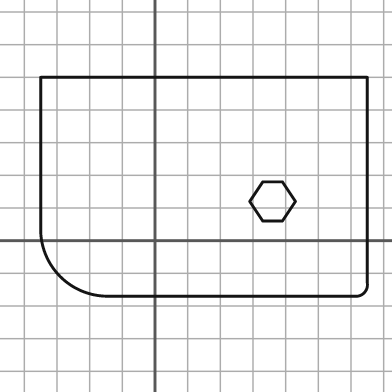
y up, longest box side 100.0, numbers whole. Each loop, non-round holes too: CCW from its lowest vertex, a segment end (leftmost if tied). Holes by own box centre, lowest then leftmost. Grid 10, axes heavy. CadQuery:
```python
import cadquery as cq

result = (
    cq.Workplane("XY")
    .moveTo(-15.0, -17.0)
    .lineTo(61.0, -17.0)
    .threePointArc((64.0, -16.0), (65.0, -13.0))
    .lineTo(65.0, 50.0)
    .lineTo(-35.0, 50.0)
    .lineTo(-35.0, 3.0)
    .threePointArc((-29.0, -11.0), (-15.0, -17.0))
    .close()
    .moveTo(33.0, 6.0)
    .lineTo(39.0, 6.0)
    .lineTo(43.0, 12.0)
    .lineTo(39.0, 18.0)
    .lineTo(33.0, 18.0)
    .lineTo(29.0, 12.0)
    .close()
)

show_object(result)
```